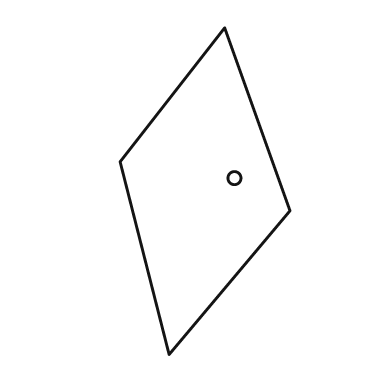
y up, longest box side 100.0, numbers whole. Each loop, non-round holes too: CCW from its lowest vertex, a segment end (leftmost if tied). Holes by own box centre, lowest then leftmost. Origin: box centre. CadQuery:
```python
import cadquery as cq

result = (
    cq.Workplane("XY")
    .moveTo(-11.0, -50.0)
    .lineTo(26.0, -6.0)
    .lineTo(6.0, 50.0)
    .lineTo(-26.0, 9.0)
    .close()
    .moveTo(9.0, 4.0)
    .circle(2.0)
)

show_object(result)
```